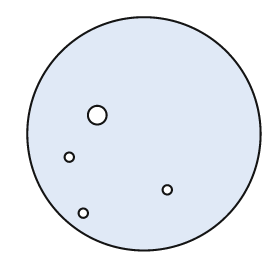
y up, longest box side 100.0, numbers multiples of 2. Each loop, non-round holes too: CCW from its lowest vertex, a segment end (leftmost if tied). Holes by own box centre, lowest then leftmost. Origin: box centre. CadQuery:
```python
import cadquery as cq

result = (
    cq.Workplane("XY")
    .moveTo(0.0, 0.0)
    .circle(50.0)
    .moveTo(-26.0, -34.0)
    .circle(2.0)
    .moveTo(10.0, -24.0)
    .circle(2.0)
    .moveTo(-32.0, -10.0)
    .circle(2.0)
    .moveTo(-20.0, 8.0)
    .circle(4.0)
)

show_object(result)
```